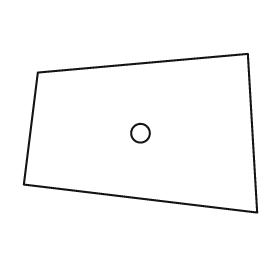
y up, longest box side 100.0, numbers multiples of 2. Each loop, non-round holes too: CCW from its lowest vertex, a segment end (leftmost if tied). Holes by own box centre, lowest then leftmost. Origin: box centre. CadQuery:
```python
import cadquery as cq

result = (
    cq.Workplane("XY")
    .moveTo(50.0, -34.0)
    .lineTo(46.0, 34.0)
    .lineTo(-44.0, 26.0)
    .lineTo(-50.0, -22.0)
    .close()
    .moveTo(0.0, 0.0)
    .circle(4.0)
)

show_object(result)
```